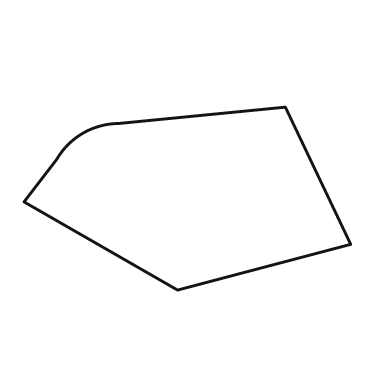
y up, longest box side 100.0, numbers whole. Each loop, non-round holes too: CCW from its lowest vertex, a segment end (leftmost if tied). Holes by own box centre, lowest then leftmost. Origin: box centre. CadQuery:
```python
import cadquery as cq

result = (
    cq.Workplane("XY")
    .moveTo(-3.0, -28.0)
    .lineTo(50.0, -14.0)
    .lineTo(30.0, 28.0)
    .lineTo(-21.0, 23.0)
    .threePointArc((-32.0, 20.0), (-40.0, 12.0))
    .lineTo(-50.0, -1.0)
    .close()
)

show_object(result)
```